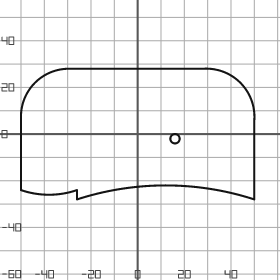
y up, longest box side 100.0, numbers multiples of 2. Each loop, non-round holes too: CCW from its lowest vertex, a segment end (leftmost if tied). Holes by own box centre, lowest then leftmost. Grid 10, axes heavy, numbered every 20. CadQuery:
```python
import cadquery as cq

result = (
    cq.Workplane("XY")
    .moveTo(-26.0, -28.0)
    .threePointArc((12.0, -22.0), (50.0, -28.0))
    .lineTo(50.0, 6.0)
    .threePointArc((44.0, 22.0), (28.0, 28.0))
    .lineTo(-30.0, 28.0)
    .threePointArc((-44.0, 22.0), (-50.0, 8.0))
    .lineTo(-50.0, -24.0)
    .threePointArc((-38.0, -26.0), (-26.0, -24.0))
    .close()
    .moveTo(16.0, -2.0)
    .circle(2.0)
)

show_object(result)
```